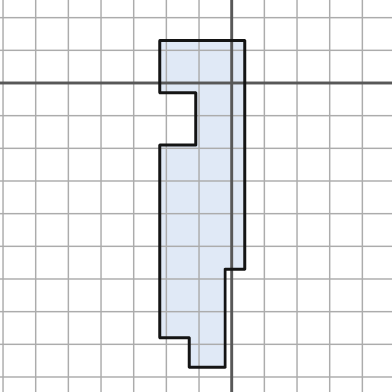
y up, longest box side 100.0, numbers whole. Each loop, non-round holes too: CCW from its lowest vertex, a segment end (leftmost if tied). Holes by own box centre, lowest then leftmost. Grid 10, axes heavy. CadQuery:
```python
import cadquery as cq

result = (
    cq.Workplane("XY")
    .moveTo(-13.0, -87.0)
    .lineTo(-2.0, -87.0)
    .lineTo(-2.0, -57.0)
    .lineTo(4.0, -57.0)
    .lineTo(4.0, 13.0)
    .lineTo(-22.0, 13.0)
    .lineTo(-22.0, -3.0)
    .lineTo(-11.0, -3.0)
    .lineTo(-11.0, -19.0)
    .lineTo(-22.0, -19.0)
    .lineTo(-22.0, -78.0)
    .lineTo(-13.0, -78.0)
    .close()
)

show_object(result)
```